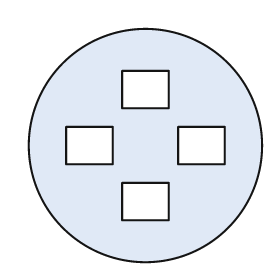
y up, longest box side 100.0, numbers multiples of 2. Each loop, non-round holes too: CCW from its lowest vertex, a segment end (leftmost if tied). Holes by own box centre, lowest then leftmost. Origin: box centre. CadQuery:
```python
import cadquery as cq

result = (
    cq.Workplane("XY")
    .moveTo(0.0, 0.0)
    .circle(50.0)
    .moveTo(-10.0, -32.0)
    .lineTo(10.0, -32.0)
    .lineTo(10.0, -16.0)
    .lineTo(-10.0, -16.0)
    .close()
    .moveTo(-34.0, -8.0)
    .lineTo(-14.0, -8.0)
    .lineTo(-14.0, 8.0)
    .lineTo(-34.0, 8.0)
    .close()
    .moveTo(14.0, -8.0)
    .lineTo(34.0, -8.0)
    .lineTo(34.0, 8.0)
    .lineTo(14.0, 8.0)
    .close()
    .moveTo(-10.0, 16.0)
    .lineTo(10.0, 16.0)
    .lineTo(10.0, 32.0)
    .lineTo(-10.0, 32.0)
    .close()
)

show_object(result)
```